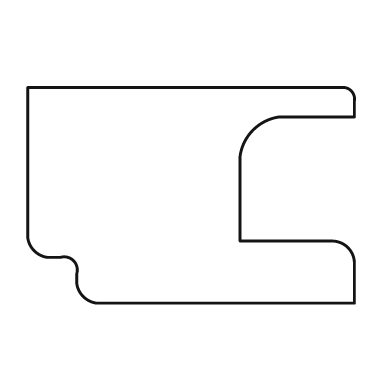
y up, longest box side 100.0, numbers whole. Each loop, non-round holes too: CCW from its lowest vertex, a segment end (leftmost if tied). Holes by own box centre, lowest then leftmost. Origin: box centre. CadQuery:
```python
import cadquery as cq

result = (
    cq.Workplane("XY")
    .moveTo(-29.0, -33.0)
    .lineTo(50.0, -33.0)
    .lineTo(50.0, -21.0)
    .threePointArc((48.0, -16.0), (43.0, -14.0))
    .lineTo(15.0, -14.0)
    .lineTo(15.0, 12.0)
    .threePointArc((19.0, 20.0), (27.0, 24.0))
    .lineTo(50.0, 24.0)
    .lineTo(50.0, 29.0)
    .threePointArc((49.0, 32.0), (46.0, 33.0))
    .lineTo(-50.0, 33.0)
    .lineTo(-50.0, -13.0)
    .threePointArc((-48.0, -17.0), (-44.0, -19.0))
    .lineTo(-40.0, -19.0)
    .threePointArc((-36.0, -20.0), (-35.0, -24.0))
    .lineTo(-35.0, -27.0)
    .threePointArc((-33.0, -31.0), (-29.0, -33.0))
    .close()
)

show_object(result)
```